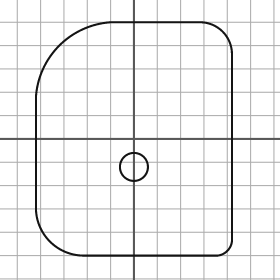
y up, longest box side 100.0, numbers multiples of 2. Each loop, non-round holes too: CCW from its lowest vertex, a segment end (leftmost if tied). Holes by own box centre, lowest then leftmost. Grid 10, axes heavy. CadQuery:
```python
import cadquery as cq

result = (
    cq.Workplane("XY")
    .moveTo(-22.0, -50.0)
    .lineTo(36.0, -50.0)
    .threePointArc((40.0, -48.0), (42.0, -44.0))
    .lineTo(42.0, 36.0)
    .threePointArc((38.0, 46.0), (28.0, 50.0))
    .lineTo(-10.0, 50.0)
    .threePointArc((-32.0, 40.0), (-42.0, 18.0))
    .lineTo(-42.0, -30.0)
    .threePointArc((-36.0, -44.0), (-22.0, -50.0))
    .close()
    .moveTo(0.0, -12.0)
    .circle(6.0)
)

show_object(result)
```